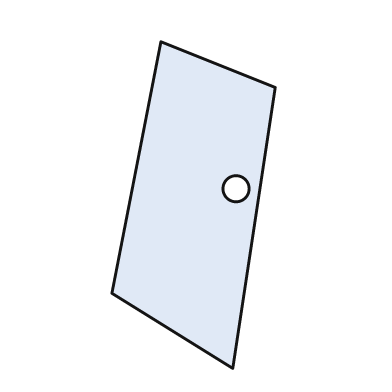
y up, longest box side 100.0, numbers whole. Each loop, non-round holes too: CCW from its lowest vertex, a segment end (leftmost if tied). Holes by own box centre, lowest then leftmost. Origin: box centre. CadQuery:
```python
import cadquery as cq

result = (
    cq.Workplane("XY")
    .moveTo(12.0, -50.0)
    .lineTo(25.0, 36.0)
    .lineTo(-10.0, 50.0)
    .lineTo(-25.0, -27.0)
    .close()
    .moveTo(13.0, 5.0)
    .circle(4.0)
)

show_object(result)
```